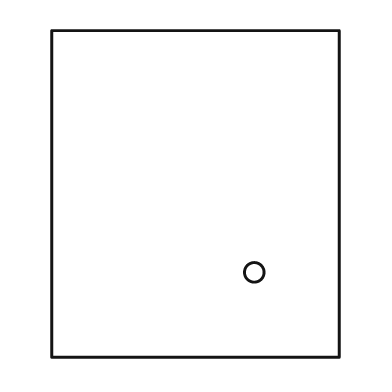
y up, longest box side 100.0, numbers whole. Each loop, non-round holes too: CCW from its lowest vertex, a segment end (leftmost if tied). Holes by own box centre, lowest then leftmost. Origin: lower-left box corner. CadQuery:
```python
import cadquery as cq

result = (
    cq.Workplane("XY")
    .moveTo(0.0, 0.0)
    .lineTo(88.0, 0.0)
    .lineTo(88.0, 100.0)
    .lineTo(0.0, 100.0)
    .close()
    .moveTo(62.0, 26.0)
    .circle(3.0)
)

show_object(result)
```